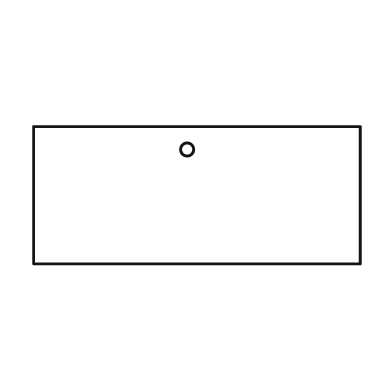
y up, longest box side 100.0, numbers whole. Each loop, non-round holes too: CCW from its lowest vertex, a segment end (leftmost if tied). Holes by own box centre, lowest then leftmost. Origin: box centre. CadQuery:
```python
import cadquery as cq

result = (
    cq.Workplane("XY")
    .moveTo(-50.0, -21.0)
    .lineTo(50.0, -21.0)
    .lineTo(50.0, 21.0)
    .lineTo(-50.0, 21.0)
    .close()
    .moveTo(-3.0, 14.0)
    .circle(2.0)
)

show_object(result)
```